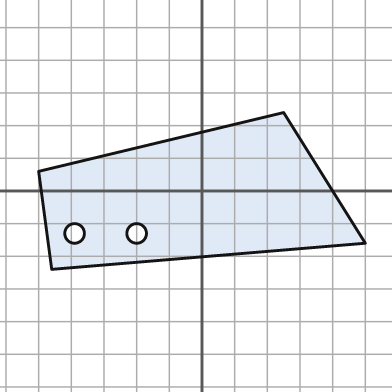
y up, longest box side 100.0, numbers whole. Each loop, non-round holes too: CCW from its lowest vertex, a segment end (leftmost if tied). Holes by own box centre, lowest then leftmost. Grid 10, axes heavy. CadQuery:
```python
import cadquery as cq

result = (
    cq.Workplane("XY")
    .moveTo(-46.0, -24.0)
    .lineTo(50.0, -16.0)
    .lineTo(25.0, 24.0)
    .lineTo(-50.0, 6.0)
    .close()
    .moveTo(-39.0, -13.0)
    .circle(3.0)
    .moveTo(-20.0, -13.0)
    .circle(3.0)
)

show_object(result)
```